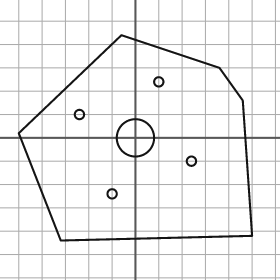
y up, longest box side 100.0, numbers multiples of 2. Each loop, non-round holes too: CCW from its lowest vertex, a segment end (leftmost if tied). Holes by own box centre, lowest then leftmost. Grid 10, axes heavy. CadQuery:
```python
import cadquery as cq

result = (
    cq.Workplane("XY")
    .moveTo(-32.0, -44.0)
    .lineTo(50.0, -42.0)
    .lineTo(46.0, 16.0)
    .lineTo(36.0, 30.0)
    .lineTo(-6.0, 44.0)
    .lineTo(-50.0, 2.0)
    .close()
    .moveTo(-10.0, -24.0)
    .circle(2.0)
    .moveTo(24.0, -10.0)
    .circle(2.0)
    .moveTo(0.0, 0.0)
    .circle(8.0)
    .moveTo(-24.0, 10.0)
    .circle(2.0)
    .moveTo(10.0, 24.0)
    .circle(2.0)
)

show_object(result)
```